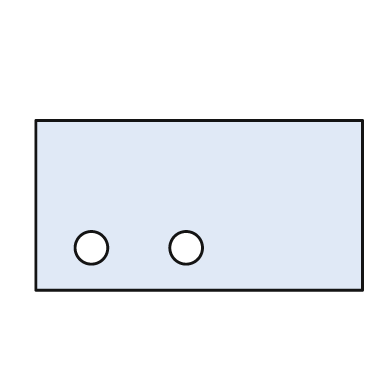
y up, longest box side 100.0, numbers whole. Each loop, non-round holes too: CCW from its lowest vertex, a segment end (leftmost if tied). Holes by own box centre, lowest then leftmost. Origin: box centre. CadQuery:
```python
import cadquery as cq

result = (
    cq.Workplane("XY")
    .moveTo(-50.0, -26.0)
    .lineTo(50.0, -26.0)
    .lineTo(50.0, 26.0)
    .lineTo(-50.0, 26.0)
    .close()
    .moveTo(-33.0, -13.0)
    .circle(5.0)
    .moveTo(-4.0, -13.0)
    .circle(5.0)
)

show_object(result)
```